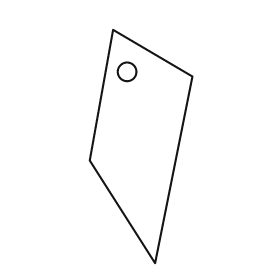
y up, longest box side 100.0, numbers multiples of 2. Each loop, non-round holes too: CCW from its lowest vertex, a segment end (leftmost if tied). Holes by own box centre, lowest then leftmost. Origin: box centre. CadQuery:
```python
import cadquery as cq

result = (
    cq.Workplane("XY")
    .moveTo(6.0, -50.0)
    .lineTo(22.0, 30.0)
    .lineTo(-12.0, 50.0)
    .lineTo(-22.0, -6.0)
    .close()
    .moveTo(-6.0, 32.0)
    .circle(4.0)
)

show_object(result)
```